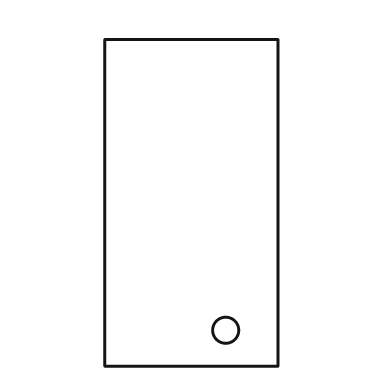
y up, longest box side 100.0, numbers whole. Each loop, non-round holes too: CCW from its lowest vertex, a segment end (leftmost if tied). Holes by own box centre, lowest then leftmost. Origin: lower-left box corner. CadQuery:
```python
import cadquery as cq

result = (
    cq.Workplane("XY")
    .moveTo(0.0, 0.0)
    .lineTo(53.0, 0.0)
    .lineTo(53.0, 100.0)
    .lineTo(0.0, 100.0)
    .close()
    .moveTo(37.0, 11.0)
    .circle(4.0)
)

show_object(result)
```